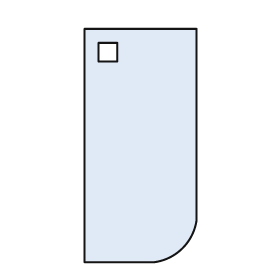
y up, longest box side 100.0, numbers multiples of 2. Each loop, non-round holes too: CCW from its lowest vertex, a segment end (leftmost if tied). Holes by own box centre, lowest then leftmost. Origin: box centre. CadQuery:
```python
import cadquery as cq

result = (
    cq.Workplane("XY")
    .moveTo(-24.0, -50.0)
    .lineTo(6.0, -50.0)
    .threePointArc((18.0, -44.0), (24.0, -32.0))
    .lineTo(24.0, 50.0)
    .lineTo(-24.0, 50.0)
    .close()
    .moveTo(-18.0, 36.0)
    .lineTo(-10.0, 36.0)
    .lineTo(-10.0, 44.0)
    .lineTo(-18.0, 44.0)
    .close()
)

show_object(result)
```